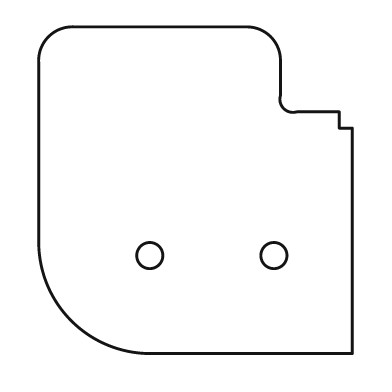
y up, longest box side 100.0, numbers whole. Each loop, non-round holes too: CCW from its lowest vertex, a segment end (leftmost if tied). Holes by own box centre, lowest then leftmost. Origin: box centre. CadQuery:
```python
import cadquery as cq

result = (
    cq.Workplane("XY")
    .moveTo(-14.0, -50.0)
    .lineTo(48.0, -50.0)
    .lineTo(48.0, 19.0)
    .lineTo(44.0, 19.0)
    .lineTo(44.0, 24.0)
    .lineTo(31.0, 24.0)
    .threePointArc((27.0, 25.0), (26.0, 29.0))
    .lineTo(26.0, 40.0)
    .threePointArc((23.0, 47.0), (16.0, 50.0))
    .lineTo(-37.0, 50.0)
    .threePointArc((-45.0, 47.0), (-48.0, 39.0))
    .lineTo(-48.0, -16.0)
    .threePointArc((-38.0, -40.0), (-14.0, -50.0))
    .close()
    .moveTo(-14.0, -20.0)
    .circle(4.0)
    .moveTo(24.0, -20.0)
    .circle(4.0)
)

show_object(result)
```